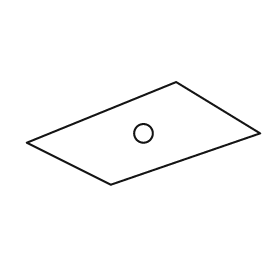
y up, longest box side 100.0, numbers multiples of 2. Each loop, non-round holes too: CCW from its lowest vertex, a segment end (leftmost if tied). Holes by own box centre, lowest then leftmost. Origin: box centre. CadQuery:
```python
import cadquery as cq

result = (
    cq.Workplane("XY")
    .moveTo(-14.0, -22.0)
    .lineTo(50.0, 0.0)
    .lineTo(14.0, 22.0)
    .lineTo(-50.0, -4.0)
    .close()
    .moveTo(0.0, 0.0)
    .circle(4.0)
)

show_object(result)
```